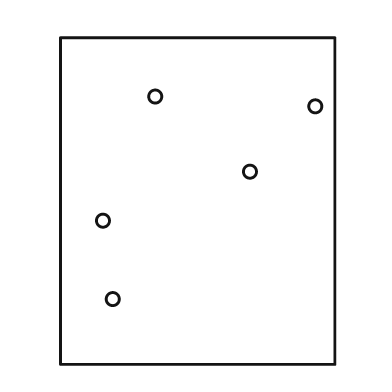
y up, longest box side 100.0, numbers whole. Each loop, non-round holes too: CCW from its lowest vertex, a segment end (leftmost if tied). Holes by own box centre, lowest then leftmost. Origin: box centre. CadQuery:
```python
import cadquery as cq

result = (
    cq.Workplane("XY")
    .moveTo(-42.0, -50.0)
    .lineTo(42.0, -50.0)
    .lineTo(42.0, 50.0)
    .lineTo(-42.0, 50.0)
    .close()
    .moveTo(-26.0, -30.0)
    .circle(2.0)
    .moveTo(-29.0, -6.0)
    .circle(2.0)
    .moveTo(16.0, 9.0)
    .circle(2.0)
    .moveTo(36.0, 29.0)
    .circle(2.0)
    .moveTo(-13.0, 32.0)
    .circle(2.0)
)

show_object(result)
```